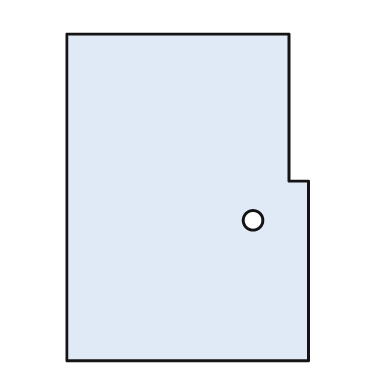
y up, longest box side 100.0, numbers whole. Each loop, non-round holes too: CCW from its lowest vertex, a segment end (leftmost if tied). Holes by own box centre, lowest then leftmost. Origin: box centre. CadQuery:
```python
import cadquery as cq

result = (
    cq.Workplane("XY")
    .moveTo(-37.0, -50.0)
    .lineTo(37.0, -50.0)
    .lineTo(37.0, 5.0)
    .lineTo(31.0, 5.0)
    .lineTo(31.0, 50.0)
    .lineTo(-37.0, 50.0)
    .close()
    .moveTo(20.0, -7.0)
    .circle(3.0)
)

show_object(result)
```